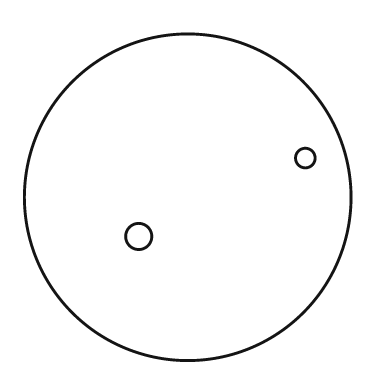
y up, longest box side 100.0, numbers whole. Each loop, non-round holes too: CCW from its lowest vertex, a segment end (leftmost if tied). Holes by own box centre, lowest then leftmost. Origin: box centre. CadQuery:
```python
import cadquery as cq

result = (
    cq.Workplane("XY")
    .moveTo(0.0, 0.0)
    .circle(50.0)
    .moveTo(-15.0, -12.0)
    .circle(4.0)
    .moveTo(36.0, 12.0)
    .circle(3.0)
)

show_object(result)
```